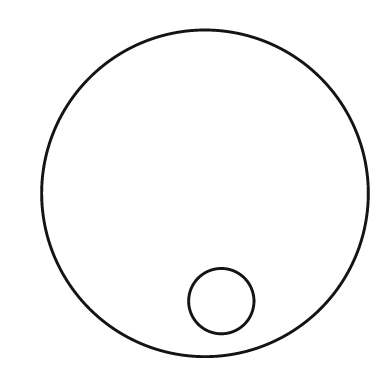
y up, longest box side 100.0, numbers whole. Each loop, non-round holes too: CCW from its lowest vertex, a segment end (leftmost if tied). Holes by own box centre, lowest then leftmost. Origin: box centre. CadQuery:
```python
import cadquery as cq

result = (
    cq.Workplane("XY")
    .moveTo(0.0, 0.0)
    .circle(50.0)
    .moveTo(5.0, -33.0)
    .circle(10.0)
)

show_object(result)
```